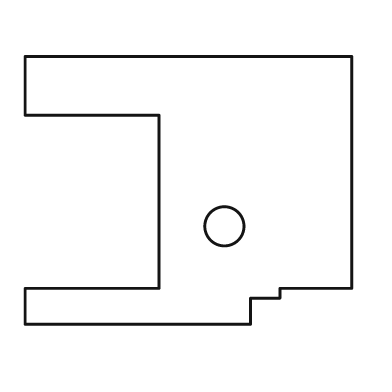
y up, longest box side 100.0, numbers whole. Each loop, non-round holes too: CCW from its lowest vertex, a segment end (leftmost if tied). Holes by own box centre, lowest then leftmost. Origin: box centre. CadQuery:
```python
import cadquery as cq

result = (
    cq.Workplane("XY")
    .moveTo(-50.0, -41.0)
    .lineTo(19.0, -41.0)
    .lineTo(19.0, -33.0)
    .lineTo(28.0, -33.0)
    .lineTo(28.0, -30.0)
    .lineTo(50.0, -30.0)
    .lineTo(50.0, 41.0)
    .lineTo(-50.0, 41.0)
    .lineTo(-50.0, 23.0)
    .lineTo(-9.0, 23.0)
    .lineTo(-9.0, -30.0)
    .lineTo(-50.0, -30.0)
    .close()
    .moveTo(11.0, -11.0)
    .circle(6.0)
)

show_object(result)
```